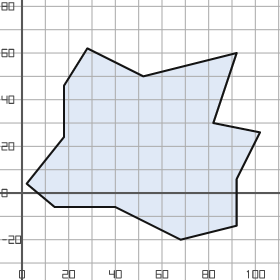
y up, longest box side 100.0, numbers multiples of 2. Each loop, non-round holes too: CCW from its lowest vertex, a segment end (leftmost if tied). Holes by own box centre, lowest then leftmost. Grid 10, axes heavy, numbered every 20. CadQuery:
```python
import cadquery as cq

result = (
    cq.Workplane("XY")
    .moveTo(68.0, -20.0)
    .lineTo(92.0, -14.0)
    .lineTo(92.0, 6.0)
    .lineTo(102.0, 26.0)
    .lineTo(82.0, 30.0)
    .lineTo(92.0, 60.0)
    .lineTo(52.0, 50.0)
    .lineTo(28.0, 62.0)
    .lineTo(18.0, 46.0)
    .lineTo(18.0, 24.0)
    .lineTo(2.0, 4.0)
    .lineTo(14.0, -6.0)
    .lineTo(40.0, -6.0)
    .close()
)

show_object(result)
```